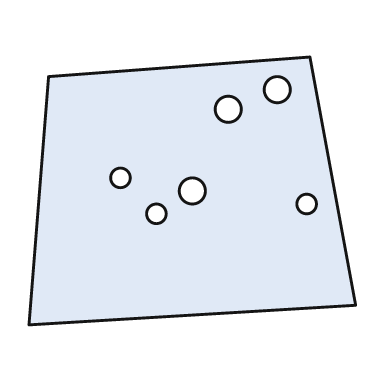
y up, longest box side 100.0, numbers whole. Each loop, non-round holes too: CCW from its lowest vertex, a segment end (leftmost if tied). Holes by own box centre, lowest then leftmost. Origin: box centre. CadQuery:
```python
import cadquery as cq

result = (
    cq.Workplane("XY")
    .moveTo(-50.0, -41.0)
    .lineTo(50.0, -35.0)
    .lineTo(36.0, 41.0)
    .lineTo(-44.0, 35.0)
    .close()
    .moveTo(-11.0, -7.0)
    .circle(3.0)
    .moveTo(35.0, -4.0)
    .circle(3.0)
    .moveTo(0.0, 0.0)
    .circle(4.0)
    .moveTo(-22.0, 4.0)
    .circle(3.0)
    .moveTo(11.0, 25.0)
    .circle(4.0)
    .moveTo(26.0, 31.0)
    .circle(4.0)
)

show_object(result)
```